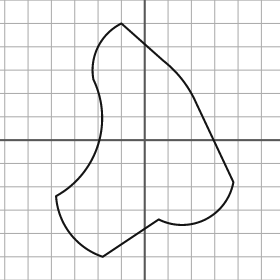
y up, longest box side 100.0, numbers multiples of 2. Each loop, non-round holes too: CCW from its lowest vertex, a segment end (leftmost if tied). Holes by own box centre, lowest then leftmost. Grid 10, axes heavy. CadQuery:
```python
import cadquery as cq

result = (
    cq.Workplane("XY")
    .moveTo(-18.0, -50.0)
    .lineTo(6.0, -34.0)
    .threePointArc((26.0, -34.0), (38.0, -18.0))
    .lineTo(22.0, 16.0)
    .threePointArc((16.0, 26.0), (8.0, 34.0))
    .lineTo(-10.0, 50.0)
    .threePointArc((-20.0, 40.0), (-22.0, 26.0))
    .threePointArc((-20.0, -2.0), (-38.0, -24.0))
    .threePointArc((-32.0, -40.0), (-18.0, -50.0))
    .close()
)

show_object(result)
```